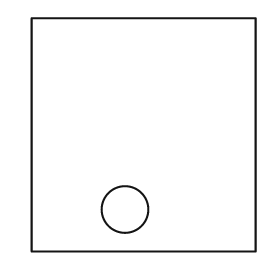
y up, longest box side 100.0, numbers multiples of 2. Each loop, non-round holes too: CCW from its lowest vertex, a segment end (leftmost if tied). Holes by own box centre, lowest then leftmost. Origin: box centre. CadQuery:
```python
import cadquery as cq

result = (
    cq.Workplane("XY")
    .moveTo(-48.0, -50.0)
    .lineTo(48.0, -50.0)
    .lineTo(48.0, 50.0)
    .lineTo(-48.0, 50.0)
    .close()
    .moveTo(-8.0, -32.0)
    .circle(10.0)
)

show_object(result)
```